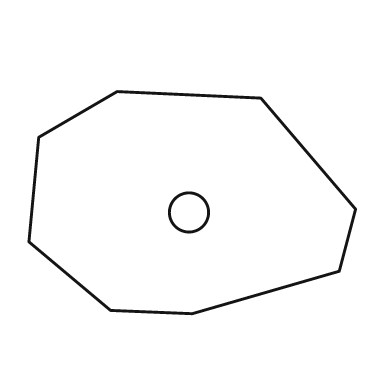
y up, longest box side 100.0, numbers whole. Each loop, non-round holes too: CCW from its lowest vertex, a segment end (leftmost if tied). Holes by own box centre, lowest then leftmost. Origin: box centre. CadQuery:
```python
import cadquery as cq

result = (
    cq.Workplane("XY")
    .moveTo(0.0, -34.0)
    .lineTo(45.0, -21.0)
    .lineTo(50.0, -2.0)
    .lineTo(21.0, 32.0)
    .lineTo(-23.0, 34.0)
    .lineTo(-47.0, 20.0)
    .lineTo(-50.0, -12.0)
    .lineTo(-25.0, -33.0)
    .close()
    .moveTo(-1.0, -3.0)
    .circle(6.0)
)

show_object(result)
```